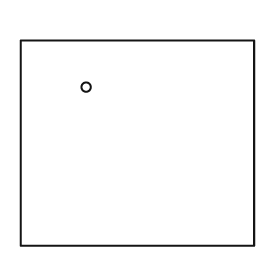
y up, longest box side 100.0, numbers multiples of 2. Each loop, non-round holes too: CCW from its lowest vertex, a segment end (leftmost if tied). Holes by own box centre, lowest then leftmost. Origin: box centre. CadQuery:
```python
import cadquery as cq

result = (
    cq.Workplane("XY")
    .moveTo(-50.0, -44.0)
    .lineTo(50.0, -44.0)
    .lineTo(50.0, 44.0)
    .lineTo(-50.0, 44.0)
    .close()
    .moveTo(-22.0, 24.0)
    .circle(2.0)
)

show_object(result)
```